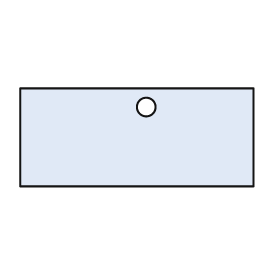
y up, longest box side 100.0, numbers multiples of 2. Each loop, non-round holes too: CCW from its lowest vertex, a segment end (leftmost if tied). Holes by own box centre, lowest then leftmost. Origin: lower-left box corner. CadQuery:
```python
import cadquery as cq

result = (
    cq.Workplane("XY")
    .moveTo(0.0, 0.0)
    .lineTo(100.0, 0.0)
    .lineTo(100.0, 42.0)
    .lineTo(0.0, 42.0)
    .close()
    .moveTo(54.0, 34.0)
    .circle(4.0)
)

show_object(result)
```